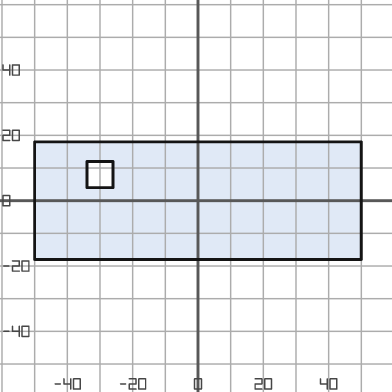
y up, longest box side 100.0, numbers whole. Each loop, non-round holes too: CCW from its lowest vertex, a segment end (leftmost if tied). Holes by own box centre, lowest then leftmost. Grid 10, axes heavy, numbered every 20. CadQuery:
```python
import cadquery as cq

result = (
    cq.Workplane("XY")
    .moveTo(-50.0, -18.0)
    .lineTo(50.0, -18.0)
    .lineTo(50.0, 18.0)
    .lineTo(-50.0, 18.0)
    .close()
    .moveTo(-34.0, 4.0)
    .lineTo(-26.0, 4.0)
    .lineTo(-26.0, 12.0)
    .lineTo(-34.0, 12.0)
    .close()
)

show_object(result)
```